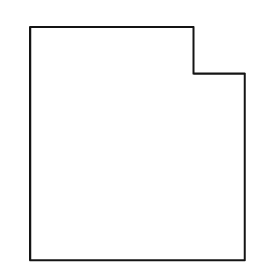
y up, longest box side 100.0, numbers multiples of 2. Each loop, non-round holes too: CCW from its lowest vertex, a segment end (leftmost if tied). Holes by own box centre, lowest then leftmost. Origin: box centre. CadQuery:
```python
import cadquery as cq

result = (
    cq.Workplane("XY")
    .moveTo(-46.0, -50.0)
    .lineTo(46.0, -50.0)
    .lineTo(46.0, 30.0)
    .lineTo(24.0, 30.0)
    .lineTo(24.0, 50.0)
    .lineTo(-46.0, 50.0)
    .close()
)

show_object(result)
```